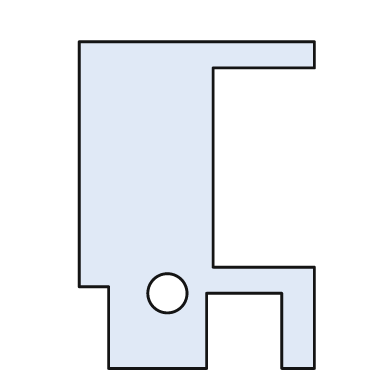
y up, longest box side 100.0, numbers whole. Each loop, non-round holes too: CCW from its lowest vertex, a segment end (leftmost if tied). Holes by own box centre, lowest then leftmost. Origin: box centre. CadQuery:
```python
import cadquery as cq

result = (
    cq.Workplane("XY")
    .moveTo(-27.0, -50.0)
    .lineTo(3.0, -50.0)
    .lineTo(3.0, -27.0)
    .lineTo(26.0, -27.0)
    .lineTo(26.0, -50.0)
    .lineTo(36.0, -50.0)
    .lineTo(36.0, -19.0)
    .lineTo(5.0, -19.0)
    .lineTo(5.0, 42.0)
    .lineTo(36.0, 42.0)
    .lineTo(36.0, 50.0)
    .lineTo(-36.0, 50.0)
    .lineTo(-36.0, -25.0)
    .lineTo(-27.0, -25.0)
    .close()
    .moveTo(-9.0, -27.0)
    .circle(6.0)
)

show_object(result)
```